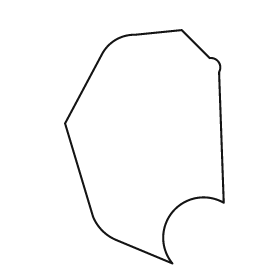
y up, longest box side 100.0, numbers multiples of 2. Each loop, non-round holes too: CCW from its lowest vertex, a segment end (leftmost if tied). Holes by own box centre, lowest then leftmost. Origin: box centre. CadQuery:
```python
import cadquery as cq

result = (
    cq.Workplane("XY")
    .moveTo(12.0, -50.0)
    .threePointArc((12.0, -28.0), (34.0, -24.0))
    .lineTo(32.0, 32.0)
    .threePointArc((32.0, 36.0), (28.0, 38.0))
    .lineTo(16.0, 50.0)
    .lineTo(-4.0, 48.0)
    .threePointArc((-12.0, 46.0), (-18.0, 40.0))
    .lineTo(-34.0, 10.0)
    .lineTo(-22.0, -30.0)
    .threePointArc((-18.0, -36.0), (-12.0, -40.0))
    .close()
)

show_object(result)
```